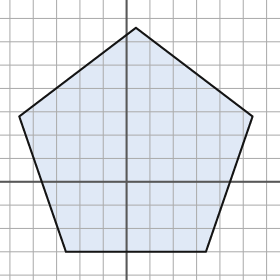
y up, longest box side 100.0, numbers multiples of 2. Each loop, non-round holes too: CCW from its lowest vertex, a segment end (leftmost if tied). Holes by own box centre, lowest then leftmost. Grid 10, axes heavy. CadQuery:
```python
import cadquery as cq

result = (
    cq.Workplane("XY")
    .moveTo(-26.0, -30.0)
    .lineTo(34.0, -30.0)
    .lineTo(54.0, 28.0)
    .lineTo(4.0, 66.0)
    .lineTo(-46.0, 28.0)
    .close()
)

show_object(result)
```